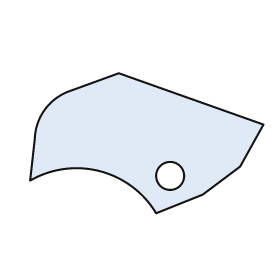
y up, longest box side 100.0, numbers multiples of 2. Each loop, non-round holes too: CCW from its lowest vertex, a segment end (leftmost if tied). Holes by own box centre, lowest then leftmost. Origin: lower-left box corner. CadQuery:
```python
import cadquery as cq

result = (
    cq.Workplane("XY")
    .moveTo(54.0, 0.0)
    .lineTo(74.0, 8.0)
    .lineTo(90.0, 20.0)
    .lineTo(100.0, 38.0)
    .lineTo(38.0, 60.0)
    .lineTo(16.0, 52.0)
    .threePointArc((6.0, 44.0), (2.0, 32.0))
    .lineTo(0.0, 14.0)
    .threePointArc((30.0, 18.0), (54.0, 0.0))
    .close()
    .moveTo(60.0, 16.0)
    .circle(6.0)
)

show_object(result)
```